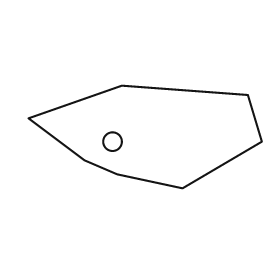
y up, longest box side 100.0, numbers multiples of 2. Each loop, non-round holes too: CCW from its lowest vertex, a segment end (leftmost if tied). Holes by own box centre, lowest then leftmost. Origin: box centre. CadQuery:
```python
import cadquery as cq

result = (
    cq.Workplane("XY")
    .moveTo(16.0, -22.0)
    .lineTo(50.0, -2.0)
    .lineTo(44.0, 18.0)
    .lineTo(-10.0, 22.0)
    .lineTo(-50.0, 8.0)
    .lineTo(-26.0, -10.0)
    .lineTo(-12.0, -16.0)
    .close()
    .moveTo(-14.0, -2.0)
    .circle(4.0)
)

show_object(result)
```